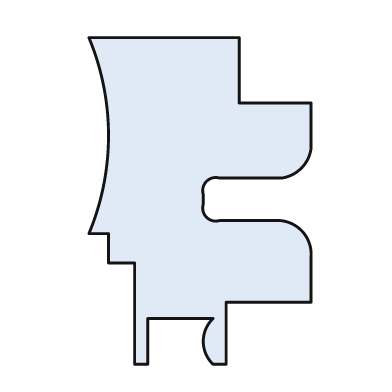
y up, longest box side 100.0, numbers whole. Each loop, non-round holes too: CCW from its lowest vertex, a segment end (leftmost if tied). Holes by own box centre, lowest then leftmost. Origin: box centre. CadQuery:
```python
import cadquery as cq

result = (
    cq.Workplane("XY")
    .moveTo(-20.0, -50.0)
    .lineTo(-16.0, -50.0)
    .lineTo(-16.0, -36.0)
    .lineTo(4.0, -36.0)
    .threePointArc((1.0, -43.0), (4.0, -50.0))
    .lineTo(8.0, -50.0)
    .lineTo(8.0, -31.0)
    .lineTo(34.0, -31.0)
    .lineTo(34.0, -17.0)
    .threePointArc((31.0, -9.0), (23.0, -6.0))
    .lineTo(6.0, -6.0)
    .threePointArc((2.0, -5.0), (1.0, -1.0))
    .lineTo(1.0, 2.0)
    .threePointArc((2.0, 6.0), (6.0, 7.0))
    .lineTo(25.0, 7.0)
    .threePointArc((31.0, 10.0), (34.0, 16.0))
    .lineTo(34.0, 30.0)
    .lineTo(12.0, 30.0)
    .lineTo(12.0, 50.0)
    .lineTo(-34.0, 50.0)
    .threePointArc((-28.0, 20.0), (-34.0, -10.0))
    .lineTo(-28.0, -10.0)
    .lineTo(-28.0, -19.0)
    .lineTo(-20.0, -19.0)
    .close()
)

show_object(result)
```